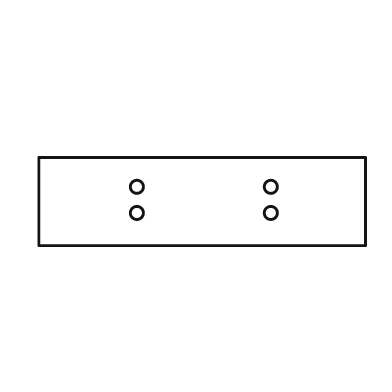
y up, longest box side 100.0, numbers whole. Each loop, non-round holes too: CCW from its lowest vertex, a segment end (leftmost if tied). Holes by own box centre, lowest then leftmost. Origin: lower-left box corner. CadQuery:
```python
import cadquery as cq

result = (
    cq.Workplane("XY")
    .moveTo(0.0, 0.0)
    .lineTo(100.0, 0.0)
    .lineTo(100.0, 27.0)
    .lineTo(0.0, 27.0)
    .close()
    .moveTo(30.0, 10.0)
    .circle(2.0)
    .moveTo(71.0, 10.0)
    .circle(2.0)
    .moveTo(30.0, 18.0)
    .circle(2.0)
    .moveTo(71.0, 18.0)
    .circle(2.0)
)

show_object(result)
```